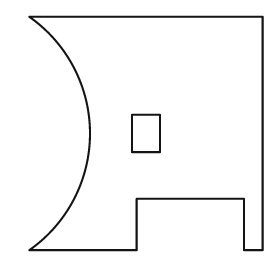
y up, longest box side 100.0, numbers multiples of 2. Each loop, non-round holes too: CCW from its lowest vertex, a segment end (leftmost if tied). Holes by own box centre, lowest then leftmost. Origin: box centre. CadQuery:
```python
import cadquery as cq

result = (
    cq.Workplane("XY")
    .moveTo(-50.0, -50.0)
    .lineTo(-4.0, -50.0)
    .lineTo(-4.0, -28.0)
    .lineTo(42.0, -28.0)
    .lineTo(42.0, -50.0)
    .lineTo(50.0, -50.0)
    .lineTo(50.0, 50.0)
    .lineTo(-50.0, 50.0)
    .threePointArc((-24.0, 0.0), (-50.0, -50.0))
    .close()
    .moveTo(-6.0, -8.0)
    .lineTo(6.0, -8.0)
    .lineTo(6.0, 8.0)
    .lineTo(-6.0, 8.0)
    .close()
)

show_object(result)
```